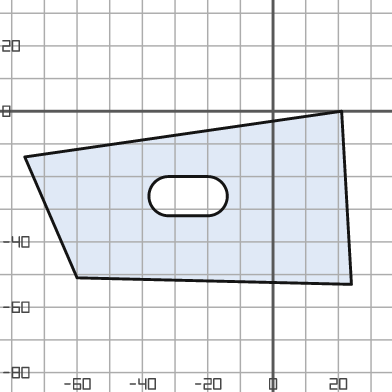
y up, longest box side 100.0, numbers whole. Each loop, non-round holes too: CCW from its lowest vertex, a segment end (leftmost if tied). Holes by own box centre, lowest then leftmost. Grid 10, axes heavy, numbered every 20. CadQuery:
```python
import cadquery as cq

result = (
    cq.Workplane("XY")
    .moveTo(24.0, -53.0)
    .lineTo(21.0, 0.0)
    .lineTo(-76.0, -14.0)
    .lineTo(-60.0, -51.0)
    .close()
    .moveTo(-32.0, -32.0)
    .lineTo(-20.0, -32.0)
    .threePointArc((-14.0, -26.0), (-20.0, -20.0))
    .lineTo(-32.0, -20.0)
    .threePointArc((-38.0, -26.0), (-32.0, -32.0))
    .close()
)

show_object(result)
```